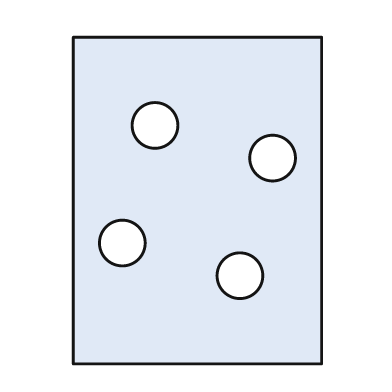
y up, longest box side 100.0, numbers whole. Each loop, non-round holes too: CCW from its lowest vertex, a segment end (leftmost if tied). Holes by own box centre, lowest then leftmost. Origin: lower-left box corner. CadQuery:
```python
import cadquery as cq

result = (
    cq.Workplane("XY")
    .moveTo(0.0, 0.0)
    .lineTo(76.0, 0.0)
    .lineTo(76.0, 100.0)
    .lineTo(0.0, 100.0)
    .close()
    .moveTo(51.0, 27.0)
    .circle(7.0)
    .moveTo(15.0, 37.0)
    .circle(7.0)
    .moveTo(61.0, 63.0)
    .circle(7.0)
    .moveTo(25.0, 73.0)
    .circle(7.0)
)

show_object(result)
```